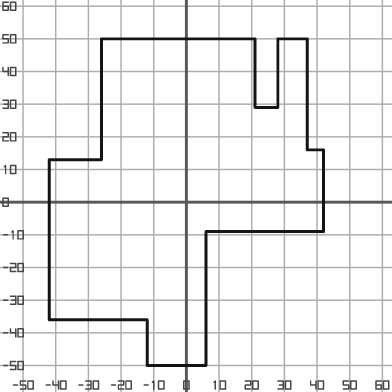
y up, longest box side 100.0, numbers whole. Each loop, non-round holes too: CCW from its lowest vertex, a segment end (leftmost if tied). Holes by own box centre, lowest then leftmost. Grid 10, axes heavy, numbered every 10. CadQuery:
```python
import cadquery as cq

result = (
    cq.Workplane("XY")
    .moveTo(-12.0, -50.0)
    .lineTo(6.0, -50.0)
    .lineTo(6.0, -9.0)
    .lineTo(42.0, -9.0)
    .lineTo(42.0, 16.0)
    .lineTo(37.0, 16.0)
    .lineTo(37.0, 50.0)
    .lineTo(28.0, 50.0)
    .lineTo(28.0, 29.0)
    .lineTo(21.0, 29.0)
    .lineTo(21.0, 50.0)
    .lineTo(-26.0, 50.0)
    .lineTo(-26.0, 13.0)
    .lineTo(-42.0, 13.0)
    .lineTo(-42.0, -36.0)
    .lineTo(-12.0, -36.0)
    .close()
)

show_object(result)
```